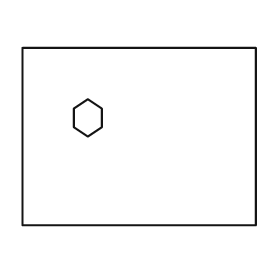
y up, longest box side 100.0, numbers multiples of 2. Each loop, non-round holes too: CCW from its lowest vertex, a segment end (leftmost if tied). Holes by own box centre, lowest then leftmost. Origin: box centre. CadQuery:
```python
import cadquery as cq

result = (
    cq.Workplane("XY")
    .moveTo(-50.0, -38.0)
    .lineTo(50.0, -38.0)
    .lineTo(50.0, 38.0)
    .lineTo(-50.0, 38.0)
    .close()
    .moveTo(-22.0, 0.0)
    .lineTo(-16.0, 4.0)
    .lineTo(-16.0, 12.0)
    .lineTo(-22.0, 16.0)
    .lineTo(-28.0, 12.0)
    .lineTo(-28.0, 4.0)
    .close()
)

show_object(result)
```